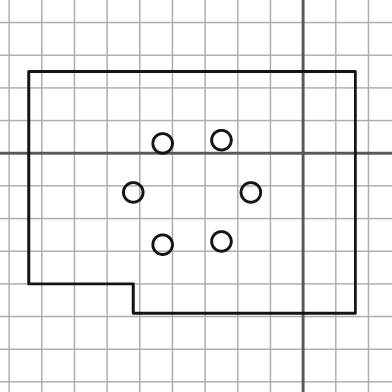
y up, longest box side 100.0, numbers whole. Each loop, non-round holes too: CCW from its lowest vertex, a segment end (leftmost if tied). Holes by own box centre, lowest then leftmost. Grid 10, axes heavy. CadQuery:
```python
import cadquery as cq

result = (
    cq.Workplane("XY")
    .moveTo(-52.0, -49.0)
    .lineTo(16.0, -49.0)
    .lineTo(16.0, 25.0)
    .lineTo(-84.0, 25.0)
    .lineTo(-84.0, -40.0)
    .lineTo(-52.0, -40.0)
    .close()
    .moveTo(-43.0, -28.0)
    .circle(3.0)
    .moveTo(-25.0, -27.0)
    .circle(3.0)
    .moveTo(-52.0, -12.0)
    .circle(3.0)
    .moveTo(-16.0, -12.0)
    .circle(3.0)
    .moveTo(-43.0, 3.0)
    .circle(3.0)
    .moveTo(-25.0, 4.0)
    .circle(3.0)
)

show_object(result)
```